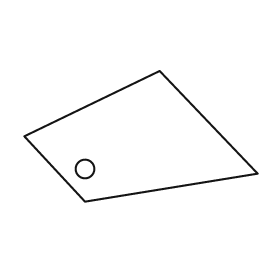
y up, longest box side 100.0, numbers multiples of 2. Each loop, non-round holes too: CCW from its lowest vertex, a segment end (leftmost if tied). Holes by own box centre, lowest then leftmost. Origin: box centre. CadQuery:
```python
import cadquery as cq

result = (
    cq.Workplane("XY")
    .moveTo(-24.0, -28.0)
    .lineTo(50.0, -16.0)
    .lineTo(8.0, 28.0)
    .lineTo(-50.0, 0.0)
    .close()
    .moveTo(-24.0, -14.0)
    .circle(4.0)
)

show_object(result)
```